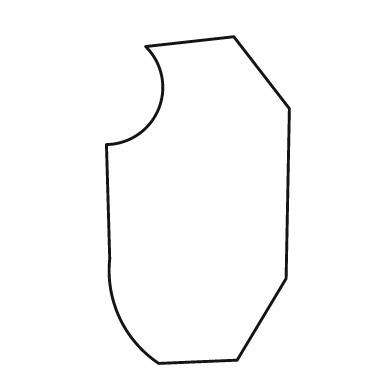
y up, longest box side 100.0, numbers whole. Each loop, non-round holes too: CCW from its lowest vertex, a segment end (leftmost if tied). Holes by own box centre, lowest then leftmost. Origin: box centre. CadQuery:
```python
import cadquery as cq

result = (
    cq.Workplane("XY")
    .moveTo(-12.0, -50.0)
    .lineTo(12.0, -49.0)
    .lineTo(27.0, -24.0)
    .lineTo(28.0, 28.0)
    .lineTo(11.0, 50.0)
    .lineTo(-16.0, 47.0)
    .threePointArc((-12.0, 28.0), (-28.0, 17.0))
    .lineTo(-27.0, -18.0)
    .threePointArc((-24.0, -36.0), (-12.0, -50.0))
    .close()
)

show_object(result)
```